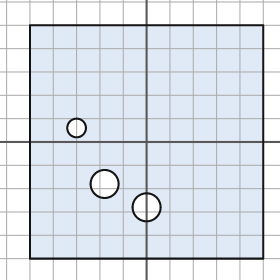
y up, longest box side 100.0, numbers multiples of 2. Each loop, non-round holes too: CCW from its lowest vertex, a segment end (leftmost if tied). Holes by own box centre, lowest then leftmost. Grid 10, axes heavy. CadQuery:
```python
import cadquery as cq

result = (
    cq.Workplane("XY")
    .moveTo(-50.0, -50.0)
    .lineTo(50.0, -50.0)
    .lineTo(50.0, 50.0)
    .lineTo(-50.0, 50.0)
    .close()
    .moveTo(0.0, -28.0)
    .circle(6.0)
    .moveTo(-18.0, -18.0)
    .circle(6.0)
    .moveTo(-30.0, 6.0)
    .circle(4.0)
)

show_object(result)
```